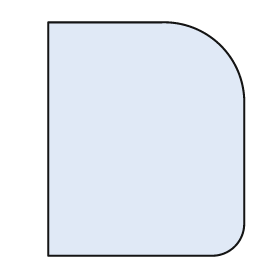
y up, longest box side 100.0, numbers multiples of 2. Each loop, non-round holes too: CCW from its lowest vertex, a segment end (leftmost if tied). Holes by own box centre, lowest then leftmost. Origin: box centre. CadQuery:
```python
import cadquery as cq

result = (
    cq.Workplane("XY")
    .moveTo(-42.0, -50.0)
    .lineTo(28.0, -50.0)
    .threePointArc((38.0, -46.0), (42.0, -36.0))
    .lineTo(42.0, 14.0)
    .threePointArc((32.0, 40.0), (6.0, 50.0))
    .lineTo(-42.0, 50.0)
    .close()
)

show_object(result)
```